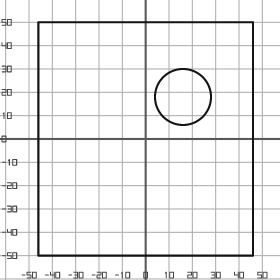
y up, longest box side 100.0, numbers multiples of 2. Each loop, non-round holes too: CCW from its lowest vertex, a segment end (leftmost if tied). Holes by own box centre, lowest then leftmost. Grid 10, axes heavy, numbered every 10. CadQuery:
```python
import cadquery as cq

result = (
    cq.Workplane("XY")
    .moveTo(-46.0, -50.0)
    .lineTo(46.0, -50.0)
    .lineTo(46.0, 50.0)
    .lineTo(-46.0, 50.0)
    .close()
    .moveTo(16.0, 18.0)
    .circle(12.0)
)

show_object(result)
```